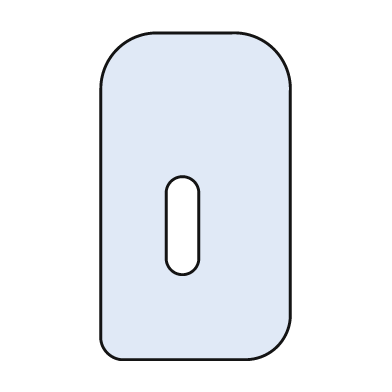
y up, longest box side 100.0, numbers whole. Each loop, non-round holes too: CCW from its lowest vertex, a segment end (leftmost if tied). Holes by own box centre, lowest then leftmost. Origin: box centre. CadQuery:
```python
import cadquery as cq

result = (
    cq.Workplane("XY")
    .moveTo(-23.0, -50.0)
    .lineTo(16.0, -50.0)
    .threePointArc((25.0, -46.0), (29.0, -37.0))
    .lineTo(29.0, 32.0)
    .threePointArc((24.0, 45.0), (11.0, 50.0))
    .lineTo(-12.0, 50.0)
    .threePointArc((-24.0, 45.0), (-29.0, 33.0))
    .lineTo(-29.0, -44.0)
    .threePointArc((-27.0, -48.0), (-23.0, -50.0))
    .close()
    .moveTo(-9.0, -19.0)
    .threePointArc((-4.0, -24.0), (1.0, -19.0))
    .lineTo(1.0, 1.0)
    .threePointArc((-4.0, 6.0), (-9.0, 1.0))
    .close()
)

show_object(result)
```